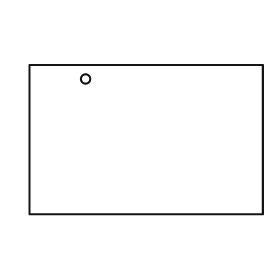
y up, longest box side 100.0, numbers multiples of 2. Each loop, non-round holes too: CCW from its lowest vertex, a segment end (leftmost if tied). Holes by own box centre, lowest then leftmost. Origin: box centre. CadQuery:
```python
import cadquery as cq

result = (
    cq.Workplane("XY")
    .moveTo(-50.0, -32.0)
    .lineTo(50.0, -32.0)
    .lineTo(50.0, 32.0)
    .lineTo(-50.0, 32.0)
    .close()
    .moveTo(-26.0, 26.0)
    .circle(2.0)
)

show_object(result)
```